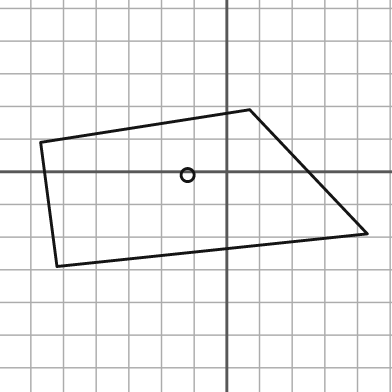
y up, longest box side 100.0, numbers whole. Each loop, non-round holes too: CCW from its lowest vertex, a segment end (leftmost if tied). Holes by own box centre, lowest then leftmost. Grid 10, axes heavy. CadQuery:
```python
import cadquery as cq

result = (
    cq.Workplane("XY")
    .moveTo(-52.0, -29.0)
    .lineTo(43.0, -19.0)
    .lineTo(7.0, 19.0)
    .lineTo(-57.0, 9.0)
    .close()
    .moveTo(-12.0, -1.0)
    .circle(2.0)
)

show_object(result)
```